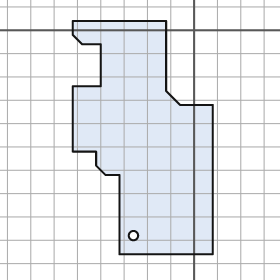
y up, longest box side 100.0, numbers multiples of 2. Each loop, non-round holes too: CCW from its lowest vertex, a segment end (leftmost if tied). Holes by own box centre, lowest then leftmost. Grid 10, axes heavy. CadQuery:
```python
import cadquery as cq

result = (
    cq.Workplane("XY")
    .moveTo(-32.0, -96.0)
    .lineTo(8.0, -96.0)
    .lineTo(8.0, -32.0)
    .lineTo(-6.0, -32.0)
    .lineTo(-12.0, -26.0)
    .lineTo(-12.0, 4.0)
    .lineTo(-52.0, 4.0)
    .lineTo(-52.0, -2.0)
    .lineTo(-48.0, -6.0)
    .lineTo(-40.0, -6.0)
    .lineTo(-40.0, -24.0)
    .lineTo(-52.0, -24.0)
    .lineTo(-52.0, -52.0)
    .lineTo(-42.0, -52.0)
    .lineTo(-42.0, -58.0)
    .lineTo(-38.0, -62.0)
    .lineTo(-32.0, -62.0)
    .close()
    .moveTo(-26.0, -88.0)
    .circle(2.0)
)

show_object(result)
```